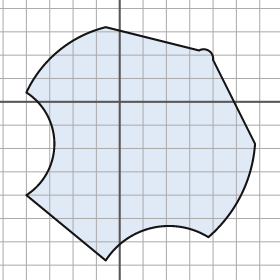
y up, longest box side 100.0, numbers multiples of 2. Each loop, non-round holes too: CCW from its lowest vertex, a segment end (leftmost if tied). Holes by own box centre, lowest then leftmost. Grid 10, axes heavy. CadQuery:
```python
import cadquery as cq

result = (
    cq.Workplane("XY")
    .moveTo(-6.0, -68.0)
    .threePointArc((14.0, -54.0), (38.0, -58.0))
    .threePointArc((52.0, -40.0), (58.0, -18.0))
    .lineTo(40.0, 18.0)
    .threePointArc((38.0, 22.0), (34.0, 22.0))
    .lineTo(-6.0, 32.0)
    .threePointArc((-26.0, 22.0), (-40.0, 4.0))
    .threePointArc((-28.0, -18.0), (-40.0, -40.0))
    .close()
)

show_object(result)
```